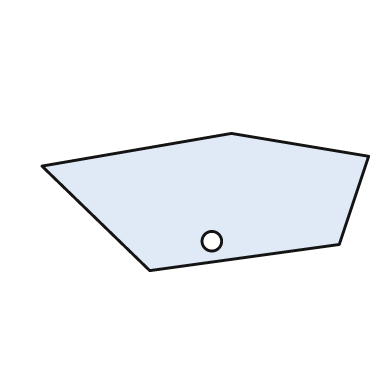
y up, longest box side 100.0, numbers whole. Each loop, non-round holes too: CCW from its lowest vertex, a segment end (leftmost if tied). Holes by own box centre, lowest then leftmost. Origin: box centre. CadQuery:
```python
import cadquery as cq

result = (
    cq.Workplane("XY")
    .moveTo(-17.0, -21.0)
    .lineTo(41.0, -13.0)
    .lineTo(50.0, 14.0)
    .lineTo(8.0, 21.0)
    .lineTo(-50.0, 11.0)
    .close()
    .moveTo(2.0, -12.0)
    .circle(3.0)
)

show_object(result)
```